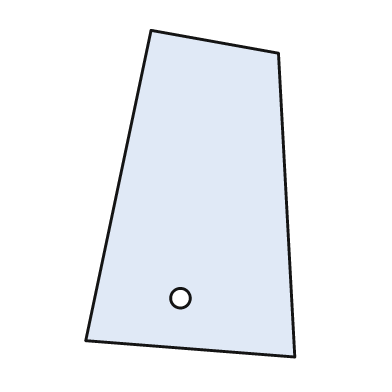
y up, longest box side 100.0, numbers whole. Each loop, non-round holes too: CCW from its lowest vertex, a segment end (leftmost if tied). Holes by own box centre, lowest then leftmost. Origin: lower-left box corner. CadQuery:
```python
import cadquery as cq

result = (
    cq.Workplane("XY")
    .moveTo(64.0, 0.0)
    .lineTo(59.0, 93.0)
    .lineTo(20.0, 100.0)
    .lineTo(0.0, 5.0)
    .close()
    .moveTo(29.0, 18.0)
    .circle(3.0)
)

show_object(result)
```